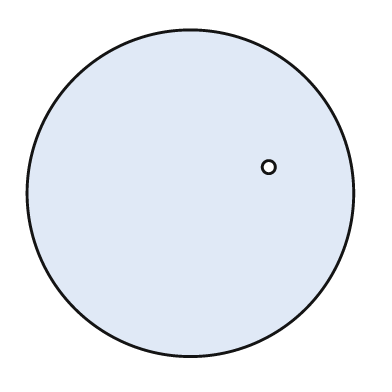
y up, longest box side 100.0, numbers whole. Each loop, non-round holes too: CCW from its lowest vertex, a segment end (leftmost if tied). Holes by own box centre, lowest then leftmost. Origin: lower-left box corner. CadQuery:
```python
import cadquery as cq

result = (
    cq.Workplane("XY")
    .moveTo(50.0, 50.0)
    .circle(50.0)
    .moveTo(74.0, 58.0)
    .circle(2.0)
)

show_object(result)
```